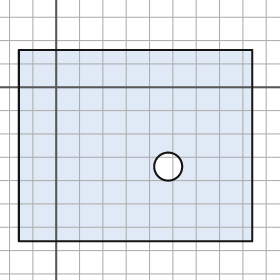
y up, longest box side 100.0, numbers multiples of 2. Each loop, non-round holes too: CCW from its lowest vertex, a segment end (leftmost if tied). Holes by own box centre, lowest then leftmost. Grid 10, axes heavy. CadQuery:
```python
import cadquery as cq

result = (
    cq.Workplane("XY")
    .moveTo(-16.0, -66.0)
    .lineTo(84.0, -66.0)
    .lineTo(84.0, 16.0)
    .lineTo(-16.0, 16.0)
    .close()
    .moveTo(48.0, -34.0)
    .circle(6.0)
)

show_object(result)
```